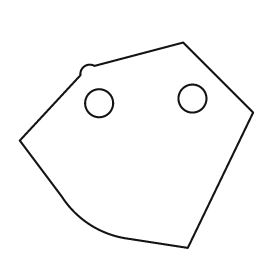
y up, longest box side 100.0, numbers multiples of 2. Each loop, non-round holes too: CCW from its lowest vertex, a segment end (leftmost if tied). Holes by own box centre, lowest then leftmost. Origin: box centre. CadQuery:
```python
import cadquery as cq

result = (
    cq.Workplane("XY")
    .moveTo(22.0, -44.0)
    .lineTo(50.0, 14.0)
    .lineTo(20.0, 44.0)
    .lineTo(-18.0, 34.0)
    .threePointArc((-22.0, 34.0), (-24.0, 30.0))
    .lineTo(-50.0, 2.0)
    .lineTo(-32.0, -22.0)
    .threePointArc((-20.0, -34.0), (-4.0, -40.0))
    .close()
    .moveTo(-16.0, 18.0)
    .circle(6.0)
    .moveTo(24.0, 20.0)
    .circle(6.0)
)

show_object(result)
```